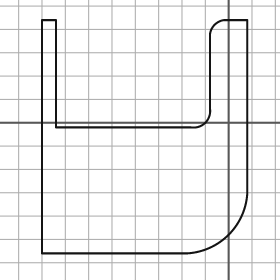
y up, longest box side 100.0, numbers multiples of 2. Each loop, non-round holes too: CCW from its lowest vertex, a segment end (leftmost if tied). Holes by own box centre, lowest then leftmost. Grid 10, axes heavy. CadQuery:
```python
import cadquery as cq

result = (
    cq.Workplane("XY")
    .moveTo(-80.0, -56.0)
    .lineTo(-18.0, -56.0)
    .threePointArc((0.0, -48.0), (8.0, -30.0))
    .lineTo(8.0, 44.0)
    .lineTo(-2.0, 44.0)
    .threePointArc((-6.0, 42.0), (-8.0, 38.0))
    .lineTo(-8.0, 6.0)
    .threePointArc((-10.0, 0.0), (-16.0, -2.0))
    .lineTo(-74.0, -2.0)
    .lineTo(-74.0, 44.0)
    .lineTo(-80.0, 44.0)
    .close()
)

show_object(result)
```